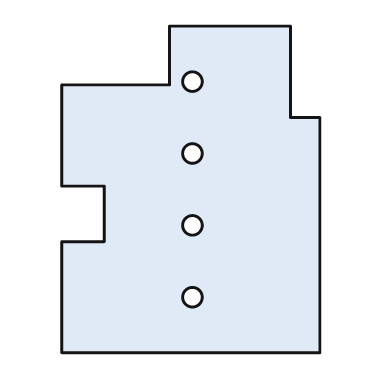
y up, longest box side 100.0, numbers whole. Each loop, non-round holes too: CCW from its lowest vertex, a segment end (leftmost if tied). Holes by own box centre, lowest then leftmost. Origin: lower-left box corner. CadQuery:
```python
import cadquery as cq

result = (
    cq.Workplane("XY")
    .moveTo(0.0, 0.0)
    .lineTo(79.0, 0.0)
    .lineTo(79.0, 72.0)
    .lineTo(70.0, 72.0)
    .lineTo(70.0, 100.0)
    .lineTo(33.0, 100.0)
    .lineTo(33.0, 82.0)
    .lineTo(0.0, 82.0)
    .lineTo(0.0, 51.0)
    .lineTo(13.0, 51.0)
    .lineTo(13.0, 34.0)
    .lineTo(0.0, 34.0)
    .close()
    .moveTo(40.0, 17.0)
    .circle(3.0)
    .moveTo(40.0, 39.0)
    .circle(3.0)
    .moveTo(40.0, 61.0)
    .circle(3.0)
    .moveTo(40.0, 83.0)
    .circle(3.0)
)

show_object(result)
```